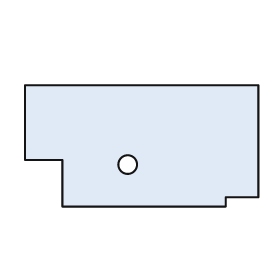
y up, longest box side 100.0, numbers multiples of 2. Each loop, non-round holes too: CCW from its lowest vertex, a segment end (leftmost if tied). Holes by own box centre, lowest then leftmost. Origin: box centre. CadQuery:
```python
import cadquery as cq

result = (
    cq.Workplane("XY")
    .moveTo(-34.0, -26.0)
    .lineTo(36.0, -26.0)
    .lineTo(36.0, -22.0)
    .lineTo(50.0, -22.0)
    .lineTo(50.0, 26.0)
    .lineTo(-50.0, 26.0)
    .lineTo(-50.0, -6.0)
    .lineTo(-34.0, -6.0)
    .close()
    .moveTo(-6.0, -8.0)
    .circle(4.0)
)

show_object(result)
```